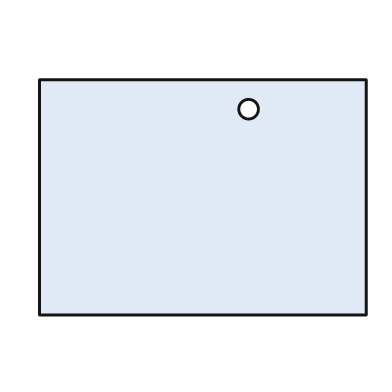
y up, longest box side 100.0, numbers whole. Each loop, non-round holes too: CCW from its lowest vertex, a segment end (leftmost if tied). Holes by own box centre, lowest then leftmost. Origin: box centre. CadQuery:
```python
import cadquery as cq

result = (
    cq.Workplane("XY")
    .moveTo(-50.0, -36.0)
    .lineTo(50.0, -36.0)
    .lineTo(50.0, 36.0)
    .lineTo(-50.0, 36.0)
    .close()
    .moveTo(14.0, 27.0)
    .circle(3.0)
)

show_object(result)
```